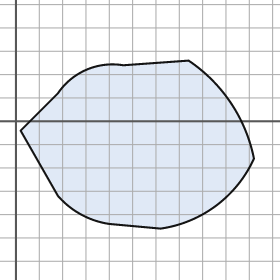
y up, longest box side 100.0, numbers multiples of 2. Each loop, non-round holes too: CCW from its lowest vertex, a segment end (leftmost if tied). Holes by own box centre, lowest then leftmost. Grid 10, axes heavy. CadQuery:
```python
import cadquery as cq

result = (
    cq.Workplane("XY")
    .moveTo(62.0, -46.0)
    .threePointArc((86.0, -36.0), (102.0, -16.0))
    .threePointArc((92.0, 8.0), (74.0, 26.0))
    .lineTo(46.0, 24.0)
    .threePointArc((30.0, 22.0), (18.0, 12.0))
    .lineTo(2.0, -4.0)
    .lineTo(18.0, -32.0)
    .threePointArc((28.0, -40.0), (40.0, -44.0))
    .close()
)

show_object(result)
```